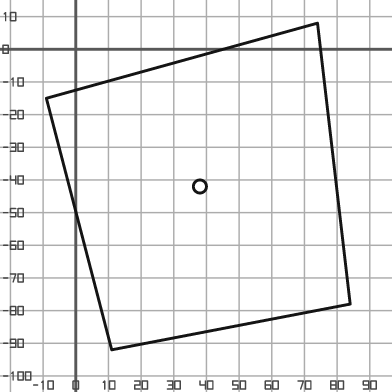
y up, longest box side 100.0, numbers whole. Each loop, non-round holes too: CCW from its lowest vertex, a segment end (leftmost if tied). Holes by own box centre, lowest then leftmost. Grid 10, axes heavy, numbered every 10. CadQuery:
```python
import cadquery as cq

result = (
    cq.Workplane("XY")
    .moveTo(11.0, -92.0)
    .lineTo(84.0, -78.0)
    .lineTo(74.0, 8.0)
    .lineTo(-9.0, -15.0)
    .close()
    .moveTo(38.0, -42.0)
    .circle(2.0)
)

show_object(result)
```